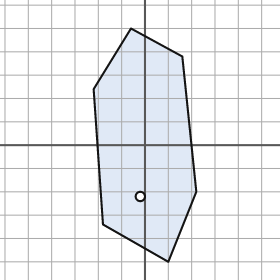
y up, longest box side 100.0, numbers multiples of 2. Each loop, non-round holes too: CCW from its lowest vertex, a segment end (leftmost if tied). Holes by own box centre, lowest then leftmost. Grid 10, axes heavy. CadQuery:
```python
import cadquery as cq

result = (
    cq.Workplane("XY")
    .moveTo(10.0, -50.0)
    .lineTo(22.0, -20.0)
    .lineTo(16.0, 38.0)
    .lineTo(-6.0, 50.0)
    .lineTo(-22.0, 24.0)
    .lineTo(-18.0, -34.0)
    .close()
    .moveTo(-2.0, -22.0)
    .circle(2.0)
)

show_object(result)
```